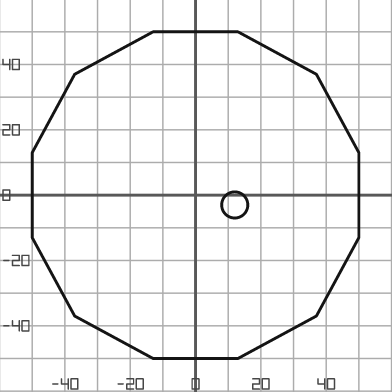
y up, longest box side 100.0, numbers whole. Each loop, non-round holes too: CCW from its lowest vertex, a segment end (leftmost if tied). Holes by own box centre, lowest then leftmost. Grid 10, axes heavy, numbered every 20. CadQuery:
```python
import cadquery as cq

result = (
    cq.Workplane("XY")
    .moveTo(-13.0, -50.0)
    .lineTo(13.0, -50.0)
    .lineTo(37.0, -37.0)
    .lineTo(50.0, -13.0)
    .lineTo(50.0, 13.0)
    .lineTo(37.0, 37.0)
    .lineTo(13.0, 50.0)
    .lineTo(-13.0, 50.0)
    .lineTo(-37.0, 37.0)
    .lineTo(-50.0, 13.0)
    .lineTo(-50.0, -13.0)
    .lineTo(-37.0, -37.0)
    .close()
    .moveTo(12.0, -3.0)
    .circle(4.0)
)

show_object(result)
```